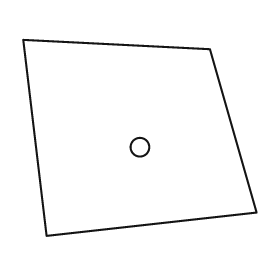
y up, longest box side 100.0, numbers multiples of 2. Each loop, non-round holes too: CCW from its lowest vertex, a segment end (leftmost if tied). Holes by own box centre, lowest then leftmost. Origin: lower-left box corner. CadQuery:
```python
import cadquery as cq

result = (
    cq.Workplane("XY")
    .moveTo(10.0, 0.0)
    .lineTo(100.0, 10.0)
    .lineTo(80.0, 80.0)
    .lineTo(0.0, 84.0)
    .close()
    .moveTo(50.0, 38.0)
    .circle(4.0)
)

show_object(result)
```